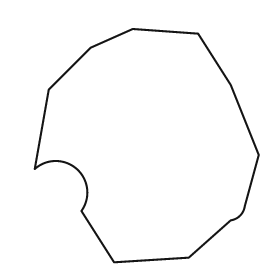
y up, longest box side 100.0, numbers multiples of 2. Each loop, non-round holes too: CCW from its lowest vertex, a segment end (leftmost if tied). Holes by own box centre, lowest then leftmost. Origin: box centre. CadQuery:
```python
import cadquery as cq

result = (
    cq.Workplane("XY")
    .moveTo(-14.0, -50.0)
    .lineTo(18.0, -48.0)
    .lineTo(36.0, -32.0)
    .threePointArc((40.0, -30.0), (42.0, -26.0))
    .lineTo(48.0, -4.0)
    .lineTo(36.0, 26.0)
    .lineTo(22.0, 48.0)
    .lineTo(-6.0, 50.0)
    .lineTo(-24.0, 42.0)
    .lineTo(-42.0, 24.0)
    .lineTo(-48.0, -10.0)
    .threePointArc((-30.0, -10.0), (-28.0, -28.0))
    .close()
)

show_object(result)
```